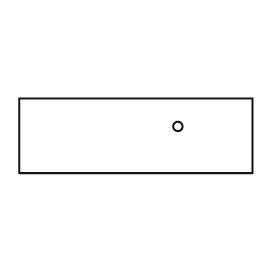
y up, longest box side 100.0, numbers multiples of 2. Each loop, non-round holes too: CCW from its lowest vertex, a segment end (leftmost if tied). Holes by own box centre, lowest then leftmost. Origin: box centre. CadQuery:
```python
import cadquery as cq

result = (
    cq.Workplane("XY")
    .moveTo(-50.0, -16.0)
    .lineTo(50.0, -16.0)
    .lineTo(50.0, 16.0)
    .lineTo(-50.0, 16.0)
    .close()
    .moveTo(18.0, 4.0)
    .circle(2.0)
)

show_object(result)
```